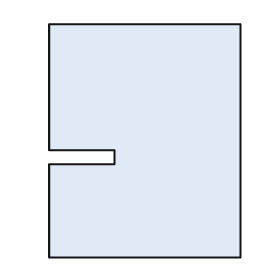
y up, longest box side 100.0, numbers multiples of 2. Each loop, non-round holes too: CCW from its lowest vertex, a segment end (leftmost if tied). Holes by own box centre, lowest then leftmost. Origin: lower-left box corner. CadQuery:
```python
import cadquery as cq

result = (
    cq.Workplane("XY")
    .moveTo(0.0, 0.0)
    .lineTo(82.0, 0.0)
    .lineTo(82.0, 100.0)
    .lineTo(0.0, 100.0)
    .lineTo(0.0, 46.0)
    .lineTo(28.0, 46.0)
    .lineTo(28.0, 40.0)
    .lineTo(0.0, 40.0)
    .close()
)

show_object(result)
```